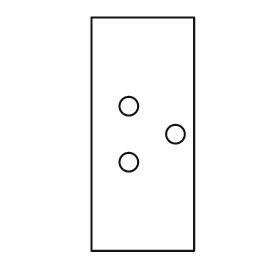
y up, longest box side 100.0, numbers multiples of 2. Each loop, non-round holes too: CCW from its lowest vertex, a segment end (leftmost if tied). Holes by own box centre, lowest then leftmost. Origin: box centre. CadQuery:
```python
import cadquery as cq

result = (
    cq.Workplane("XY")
    .moveTo(-22.0, -50.0)
    .lineTo(22.0, -50.0)
    .lineTo(22.0, 50.0)
    .lineTo(-22.0, 50.0)
    .close()
    .moveTo(-6.0, -12.0)
    .circle(4.0)
    .moveTo(14.0, 0.0)
    .circle(4.0)
    .moveTo(-6.0, 12.0)
    .circle(4.0)
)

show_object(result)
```